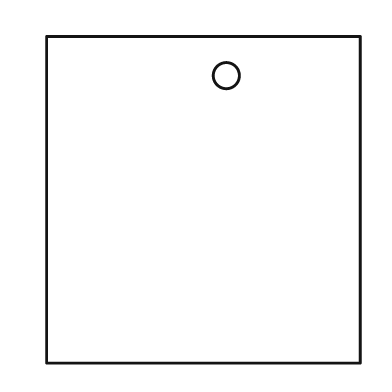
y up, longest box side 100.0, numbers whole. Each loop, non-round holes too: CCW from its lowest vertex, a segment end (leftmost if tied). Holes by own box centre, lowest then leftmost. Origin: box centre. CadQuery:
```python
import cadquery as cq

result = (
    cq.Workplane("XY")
    .moveTo(-48.0, -50.0)
    .lineTo(48.0, -50.0)
    .lineTo(48.0, 50.0)
    .lineTo(-48.0, 50.0)
    .close()
    .moveTo(7.0, 38.0)
    .circle(4.0)
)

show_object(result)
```